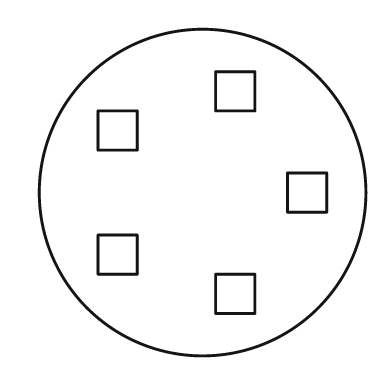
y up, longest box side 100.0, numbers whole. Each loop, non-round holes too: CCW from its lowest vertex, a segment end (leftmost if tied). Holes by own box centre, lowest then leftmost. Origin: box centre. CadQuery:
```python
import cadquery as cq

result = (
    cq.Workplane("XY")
    .moveTo(0.0, 0.0)
    .circle(50.0)
    .moveTo(4.0, -37.0)
    .lineTo(16.0, -37.0)
    .lineTo(16.0, -25.0)
    .lineTo(4.0, -25.0)
    .close()
    .moveTo(-32.0, -25.0)
    .lineTo(-20.0, -25.0)
    .lineTo(-20.0, -13.0)
    .lineTo(-32.0, -13.0)
    .close()
    .moveTo(26.0, -6.0)
    .lineTo(38.0, -6.0)
    .lineTo(38.0, 6.0)
    .lineTo(26.0, 6.0)
    .close()
    .moveTo(-32.0, 13.0)
    .lineTo(-20.0, 13.0)
    .lineTo(-20.0, 25.0)
    .lineTo(-32.0, 25.0)
    .close()
    .moveTo(4.0, 25.0)
    .lineTo(16.0, 25.0)
    .lineTo(16.0, 37.0)
    .lineTo(4.0, 37.0)
    .close()
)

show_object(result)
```